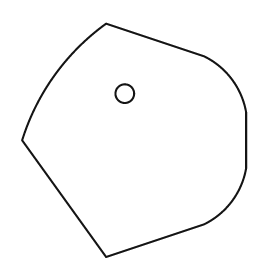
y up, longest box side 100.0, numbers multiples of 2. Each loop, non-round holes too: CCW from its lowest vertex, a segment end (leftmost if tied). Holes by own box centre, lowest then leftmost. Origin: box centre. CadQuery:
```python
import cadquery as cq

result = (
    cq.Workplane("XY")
    .moveTo(-12.0, -50.0)
    .lineTo(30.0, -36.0)
    .threePointArc((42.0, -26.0), (48.0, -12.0))
    .lineTo(48.0, 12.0)
    .threePointArc((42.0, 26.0), (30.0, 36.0))
    .lineTo(-12.0, 50.0)
    .threePointArc((-34.0, 28.0), (-48.0, 0.0))
    .close()
    .moveTo(-4.0, 20.0)
    .circle(4.0)
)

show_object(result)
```